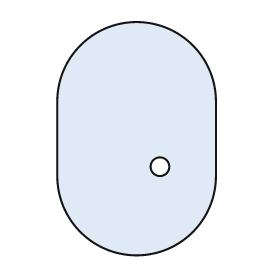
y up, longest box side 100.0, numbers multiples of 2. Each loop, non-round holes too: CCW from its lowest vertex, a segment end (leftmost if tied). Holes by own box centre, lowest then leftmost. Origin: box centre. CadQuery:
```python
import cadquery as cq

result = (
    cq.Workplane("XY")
    .moveTo(-34.0, -16.0)
    .threePointArc((0.0, -50.0), (34.0, -16.0))
    .lineTo(34.0, 16.0)
    .threePointArc((0.0, 50.0), (-34.0, 16.0))
    .close()
    .moveTo(10.0, -12.0)
    .circle(4.0)
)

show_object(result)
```